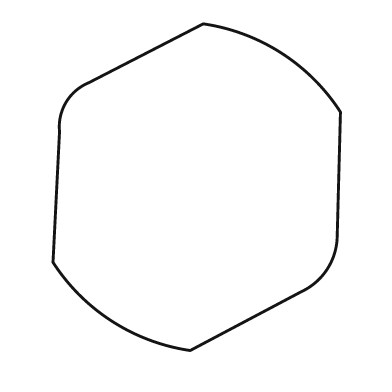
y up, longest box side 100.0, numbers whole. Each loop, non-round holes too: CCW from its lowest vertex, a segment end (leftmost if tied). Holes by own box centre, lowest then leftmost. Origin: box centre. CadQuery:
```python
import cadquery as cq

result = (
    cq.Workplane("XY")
    .moveTo(-2.0, -50.0)
    .lineTo(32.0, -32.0)
    .threePointArc((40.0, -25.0), (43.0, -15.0))
    .lineTo(44.0, 23.0)
    .threePointArc((26.0, 41.0), (2.0, 50.0))
    .lineTo(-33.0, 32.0)
    .threePointArc((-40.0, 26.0), (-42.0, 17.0))
    .lineTo(-44.0, -23.0)
    .threePointArc((-26.0, -41.0), (-2.0, -50.0))
    .close()
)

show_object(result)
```